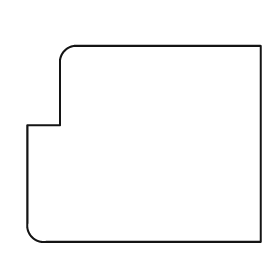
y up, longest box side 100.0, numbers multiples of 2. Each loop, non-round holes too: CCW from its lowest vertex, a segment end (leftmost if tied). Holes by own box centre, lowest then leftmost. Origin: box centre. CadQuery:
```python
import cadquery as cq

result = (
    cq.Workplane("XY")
    .moveTo(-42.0, -42.0)
    .lineTo(50.0, -42.0)
    .lineTo(50.0, 42.0)
    .lineTo(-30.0, 42.0)
    .threePointArc((-34.0, 40.0), (-36.0, 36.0))
    .lineTo(-36.0, 8.0)
    .lineTo(-50.0, 8.0)
    .lineTo(-50.0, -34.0)
    .threePointArc((-48.0, -40.0), (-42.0, -42.0))
    .close()
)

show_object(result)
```